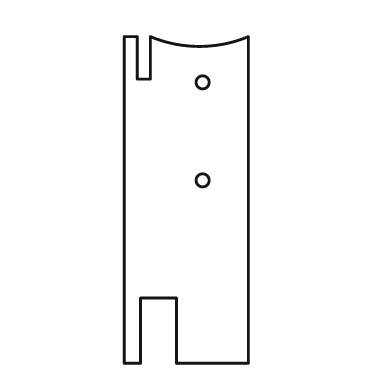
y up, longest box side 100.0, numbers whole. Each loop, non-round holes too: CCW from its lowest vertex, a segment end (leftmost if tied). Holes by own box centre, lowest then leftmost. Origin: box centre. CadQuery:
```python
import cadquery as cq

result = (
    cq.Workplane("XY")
    .moveTo(-19.0, -50.0)
    .lineTo(-14.0, -50.0)
    .lineTo(-14.0, -30.0)
    .lineTo(-3.0, -30.0)
    .lineTo(-3.0, -50.0)
    .lineTo(19.0, -50.0)
    .lineTo(19.0, 50.0)
    .threePointArc((4.0, 47.0), (-11.0, 50.0))
    .lineTo(-11.0, 37.0)
    .lineTo(-15.0, 37.0)
    .lineTo(-15.0, 50.0)
    .lineTo(-19.0, 50.0)
    .close()
    .moveTo(5.0, 6.0)
    .circle(2.0)
    .moveTo(5.0, 36.0)
    .circle(2.0)
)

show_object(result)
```